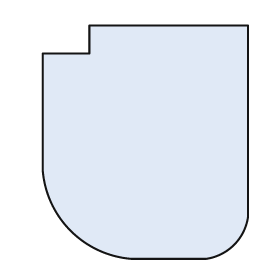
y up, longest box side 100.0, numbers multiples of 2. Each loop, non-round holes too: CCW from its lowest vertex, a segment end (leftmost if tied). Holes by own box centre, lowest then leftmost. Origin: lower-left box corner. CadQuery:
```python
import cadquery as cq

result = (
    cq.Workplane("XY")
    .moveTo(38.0, 0.0)
    .lineTo(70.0, 0.0)
    .threePointArc((82.0, 6.0), (88.0, 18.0))
    .lineTo(88.0, 100.0)
    .lineTo(20.0, 100.0)
    .lineTo(20.0, 88.0)
    .lineTo(0.0, 88.0)
    .lineTo(0.0, 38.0)
    .threePointArc((12.0, 12.0), (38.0, 0.0))
    .close()
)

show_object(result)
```